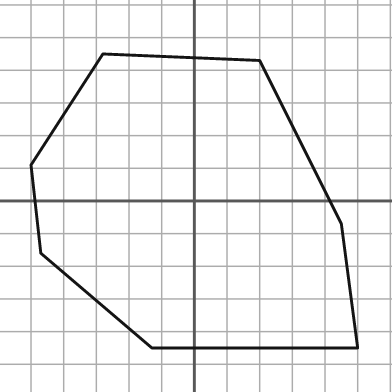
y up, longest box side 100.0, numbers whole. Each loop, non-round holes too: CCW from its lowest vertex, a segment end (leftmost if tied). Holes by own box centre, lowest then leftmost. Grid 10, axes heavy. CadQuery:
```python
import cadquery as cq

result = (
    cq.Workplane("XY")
    .moveTo(-13.0, -45.0)
    .lineTo(50.0, -45.0)
    .lineTo(45.0, -7.0)
    .lineTo(20.0, 43.0)
    .lineTo(-28.0, 45.0)
    .lineTo(-50.0, 11.0)
    .lineTo(-47.0, -16.0)
    .close()
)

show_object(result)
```